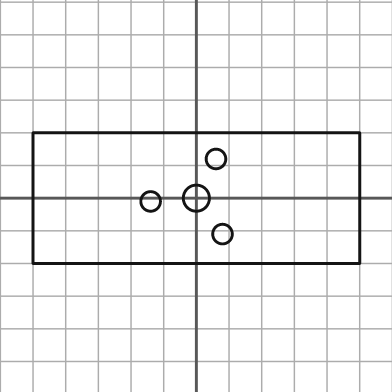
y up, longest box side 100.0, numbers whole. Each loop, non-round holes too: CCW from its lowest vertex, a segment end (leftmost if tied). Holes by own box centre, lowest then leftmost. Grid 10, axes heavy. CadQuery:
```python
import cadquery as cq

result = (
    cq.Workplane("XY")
    .moveTo(-50.0, -20.0)
    .lineTo(50.0, -20.0)
    .lineTo(50.0, 20.0)
    .lineTo(-50.0, 20.0)
    .close()
    .moveTo(8.0, -11.0)
    .circle(3.0)
    .moveTo(-14.0, -1.0)
    .circle(3.0)
    .moveTo(0.0, 0.0)
    .circle(4.0)
    .moveTo(6.0, 12.0)
    .circle(3.0)
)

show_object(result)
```